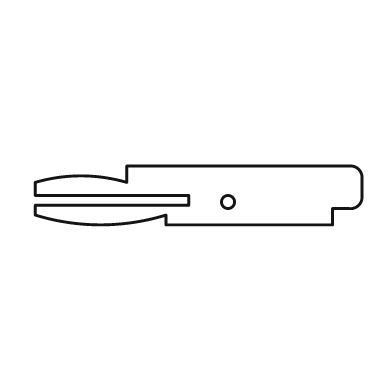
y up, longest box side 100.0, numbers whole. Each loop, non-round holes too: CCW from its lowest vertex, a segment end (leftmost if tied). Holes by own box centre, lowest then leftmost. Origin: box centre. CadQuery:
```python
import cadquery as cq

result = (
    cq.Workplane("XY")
    .moveTo(-10.0, -9.0)
    .lineTo(41.0, -9.0)
    .lineTo(41.0, -4.0)
    .lineTo(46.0, -4.0)
    .threePointArc((49.0, -3.0), (50.0, 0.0))
    .lineTo(50.0, 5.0)
    .threePointArc((49.0, 8.0), (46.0, 9.0))
    .lineTo(-22.0, 9.0)
    .lineTo(-22.0, 4.0)
    .threePointArc((-36.0, 6.0), (-50.0, 4.0))
    .lineTo(-50.0, 0.0)
    .lineTo(-3.0, 0.0)
    .lineTo(-3.0, -3.0)
    .lineTo(-50.0, -3.0)
    .lineTo(-50.0, -6.0)
    .threePointArc((-30.0, -9.0), (-10.0, -6.0))
    .close()
    .moveTo(9.0, -2.0)
    .circle(2.0)
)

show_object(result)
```